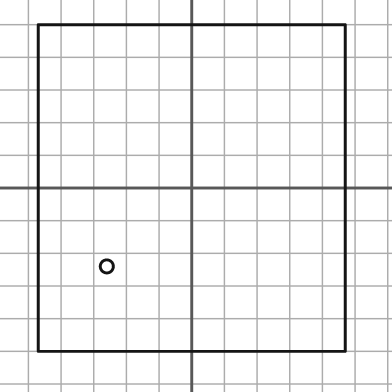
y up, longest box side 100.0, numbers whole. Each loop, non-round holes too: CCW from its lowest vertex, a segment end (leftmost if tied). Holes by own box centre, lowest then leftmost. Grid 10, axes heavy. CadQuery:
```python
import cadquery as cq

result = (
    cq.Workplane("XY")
    .moveTo(-47.0, -50.0)
    .lineTo(47.0, -50.0)
    .lineTo(47.0, 50.0)
    .lineTo(-47.0, 50.0)
    .close()
    .moveTo(-26.0, -24.0)
    .circle(2.0)
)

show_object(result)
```